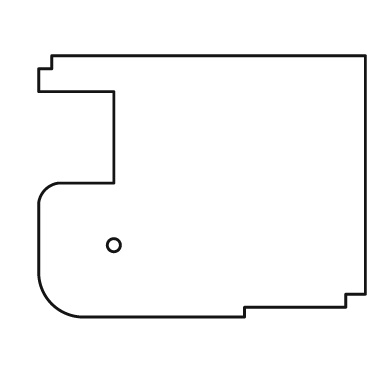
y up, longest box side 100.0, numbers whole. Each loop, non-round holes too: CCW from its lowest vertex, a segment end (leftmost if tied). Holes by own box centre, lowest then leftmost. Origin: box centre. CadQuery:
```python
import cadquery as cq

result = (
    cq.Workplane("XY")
    .moveTo(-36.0, -40.0)
    .lineTo(13.0, -40.0)
    .lineTo(13.0, -37.0)
    .lineTo(44.0, -37.0)
    .lineTo(44.0, -33.0)
    .lineTo(50.0, -33.0)
    .lineTo(50.0, 40.0)
    .lineTo(-46.0, 40.0)
    .lineTo(-46.0, 36.0)
    .lineTo(-50.0, 36.0)
    .lineTo(-50.0, 29.0)
    .lineTo(-27.0, 29.0)
    .lineTo(-27.0, 1.0)
    .lineTo(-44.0, 1.0)
    .threePointArc((-48.0, -1.0), (-50.0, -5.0))
    .lineTo(-50.0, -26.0)
    .threePointArc((-46.0, -36.0), (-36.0, -40.0))
    .close()
    .moveTo(-27.0, -18.0)
    .circle(2.0)
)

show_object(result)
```